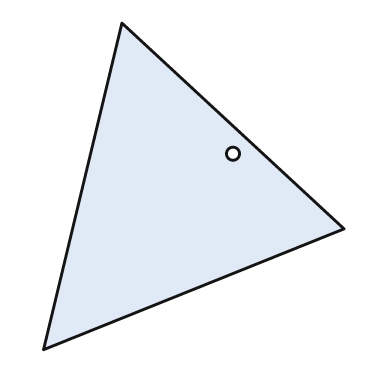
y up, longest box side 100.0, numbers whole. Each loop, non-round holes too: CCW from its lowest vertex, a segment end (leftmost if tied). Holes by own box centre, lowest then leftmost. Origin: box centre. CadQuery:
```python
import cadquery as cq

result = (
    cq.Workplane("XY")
    .moveTo(-46.0, -50.0)
    .lineTo(46.0, -13.0)
    .lineTo(-22.0, 50.0)
    .close()
    .moveTo(12.0, 10.0)
    .circle(2.0)
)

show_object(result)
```